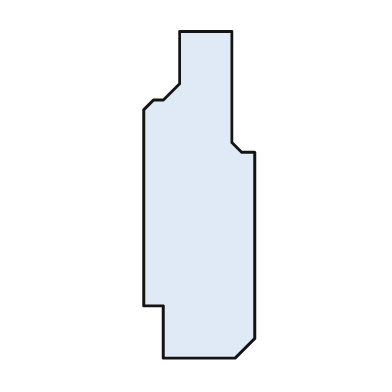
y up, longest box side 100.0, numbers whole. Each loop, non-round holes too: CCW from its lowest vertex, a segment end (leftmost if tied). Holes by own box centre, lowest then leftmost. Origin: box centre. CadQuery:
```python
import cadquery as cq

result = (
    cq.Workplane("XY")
    .moveTo(-11.0, -50.0)
    .lineTo(11.0, -50.0)
    .lineTo(17.0, -44.0)
    .lineTo(17.0, 13.0)
    .lineTo(13.0, 13.0)
    .lineTo(10.0, 16.0)
    .lineTo(10.0, 50.0)
    .lineTo(-6.0, 50.0)
    .lineTo(-6.0, 34.0)
    .lineTo(-11.0, 29.0)
    .lineTo(-14.0, 29.0)
    .lineTo(-17.0, 26.0)
    .lineTo(-17.0, -34.0)
    .lineTo(-11.0, -34.0)
    .close()
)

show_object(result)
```